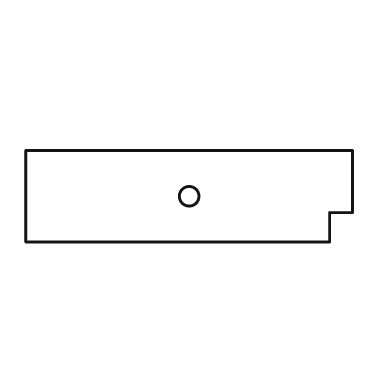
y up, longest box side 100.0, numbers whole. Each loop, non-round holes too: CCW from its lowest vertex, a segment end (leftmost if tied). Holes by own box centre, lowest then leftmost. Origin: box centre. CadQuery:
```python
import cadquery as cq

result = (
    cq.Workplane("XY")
    .moveTo(-50.0, -14.0)
    .lineTo(43.0, -14.0)
    .lineTo(43.0, -5.0)
    .lineTo(50.0, -5.0)
    .lineTo(50.0, 14.0)
    .lineTo(-50.0, 14.0)
    .close()
    .moveTo(0.0, 0.0)
    .circle(3.0)
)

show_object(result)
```